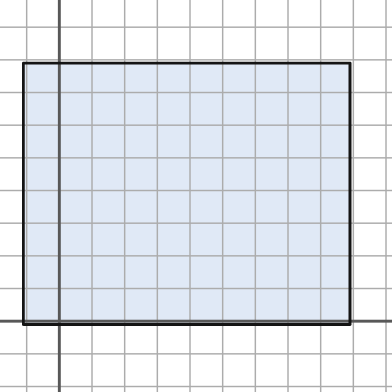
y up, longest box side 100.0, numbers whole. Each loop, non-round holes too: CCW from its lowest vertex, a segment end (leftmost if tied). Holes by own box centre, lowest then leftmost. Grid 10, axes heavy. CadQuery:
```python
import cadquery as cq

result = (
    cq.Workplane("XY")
    .moveTo(-11.0, -1.0)
    .lineTo(89.0, -1.0)
    .lineTo(89.0, 79.0)
    .lineTo(-11.0, 79.0)
    .close()
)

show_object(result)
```